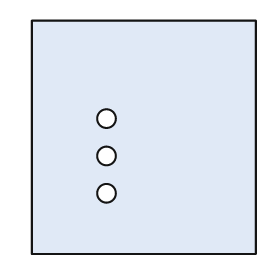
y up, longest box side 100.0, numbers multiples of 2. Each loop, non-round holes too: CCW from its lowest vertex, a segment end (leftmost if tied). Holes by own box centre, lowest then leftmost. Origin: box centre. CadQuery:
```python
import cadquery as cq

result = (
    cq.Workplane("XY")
    .moveTo(-48.0, -50.0)
    .lineTo(48.0, -50.0)
    .lineTo(48.0, 50.0)
    .lineTo(-48.0, 50.0)
    .close()
    .moveTo(-16.0, -24.0)
    .circle(4.0)
    .moveTo(-16.0, -8.0)
    .circle(4.0)
    .moveTo(-16.0, 8.0)
    .circle(4.0)
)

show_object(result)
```